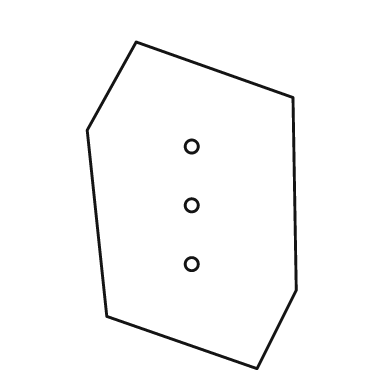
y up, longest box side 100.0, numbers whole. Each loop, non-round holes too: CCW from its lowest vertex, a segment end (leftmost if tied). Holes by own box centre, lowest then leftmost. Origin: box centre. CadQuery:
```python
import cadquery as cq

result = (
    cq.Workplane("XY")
    .moveTo(20.0, -50.0)
    .lineTo(32.0, -26.0)
    .lineTo(31.0, 33.0)
    .lineTo(-17.0, 50.0)
    .lineTo(-32.0, 23.0)
    .lineTo(-26.0, -34.0)
    .close()
    .moveTo(0.0, -18.0)
    .circle(2.0)
    .moveTo(0.0, 0.0)
    .circle(2.0)
    .moveTo(0.0, 18.0)
    .circle(2.0)
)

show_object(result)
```